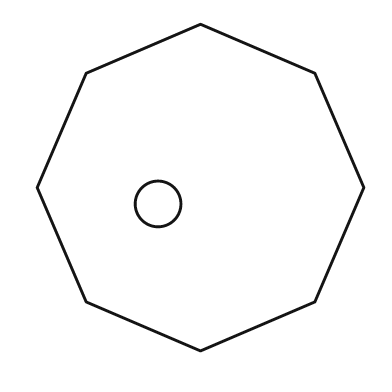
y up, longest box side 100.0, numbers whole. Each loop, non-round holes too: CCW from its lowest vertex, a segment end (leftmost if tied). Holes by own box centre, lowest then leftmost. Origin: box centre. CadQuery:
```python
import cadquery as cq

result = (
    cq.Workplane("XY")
    .moveTo(0.0, -50.0)
    .lineTo(35.0, -35.0)
    .lineTo(50.0, 0.0)
    .lineTo(35.0, 35.0)
    .lineTo(0.0, 50.0)
    .lineTo(-35.0, 35.0)
    .lineTo(-50.0, 0.0)
    .lineTo(-35.0, -35.0)
    .close()
    .moveTo(-13.0, -5.0)
    .circle(7.0)
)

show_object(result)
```